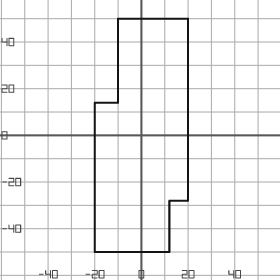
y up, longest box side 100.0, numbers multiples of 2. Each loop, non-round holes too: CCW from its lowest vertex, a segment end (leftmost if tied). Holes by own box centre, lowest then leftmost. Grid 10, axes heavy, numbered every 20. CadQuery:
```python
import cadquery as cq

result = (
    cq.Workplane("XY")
    .moveTo(-20.0, -50.0)
    .lineTo(12.0, -50.0)
    .lineTo(12.0, -28.0)
    .lineTo(20.0, -28.0)
    .lineTo(20.0, 50.0)
    .lineTo(-10.0, 50.0)
    .lineTo(-10.0, 14.0)
    .lineTo(-20.0, 14.0)
    .close()
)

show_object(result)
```